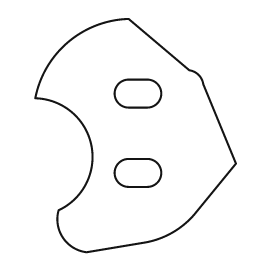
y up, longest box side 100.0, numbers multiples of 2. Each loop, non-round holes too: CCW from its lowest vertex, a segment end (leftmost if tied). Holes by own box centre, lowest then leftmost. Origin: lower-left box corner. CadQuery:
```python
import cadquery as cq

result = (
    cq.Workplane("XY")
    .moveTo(22.0, 0.0)
    .lineTo(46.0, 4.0)
    .threePointArc((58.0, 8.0), (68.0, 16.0))
    .lineTo(86.0, 38.0)
    .lineTo(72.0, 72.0)
    .threePointArc((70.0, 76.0), (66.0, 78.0))
    .lineTo(40.0, 100.0)
    .threePointArc((14.0, 90.0), (0.0, 66.0))
    .threePointArc((24.0, 46.0), (10.0, 18.0))
    .threePointArc((12.0, 6.0), (22.0, 0.0))
    .close()
    .moveTo(40.0, 28.0)
    .lineTo(48.0, 28.0)
    .threePointArc((54.0, 34.0), (48.0, 40.0))
    .lineTo(40.0, 40.0)
    .threePointArc((34.0, 34.0), (40.0, 28.0))
    .close()
    .moveTo(40.0, 62.0)
    .lineTo(48.0, 62.0)
    .threePointArc((54.0, 68.0), (48.0, 74.0))
    .lineTo(40.0, 74.0)
    .threePointArc((34.0, 68.0), (40.0, 62.0))
    .close()
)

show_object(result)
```